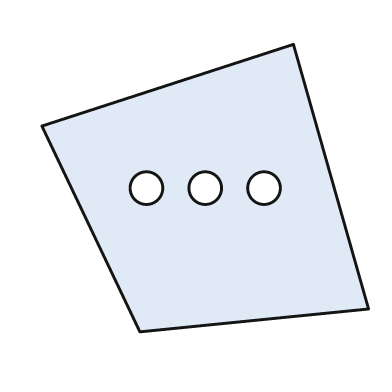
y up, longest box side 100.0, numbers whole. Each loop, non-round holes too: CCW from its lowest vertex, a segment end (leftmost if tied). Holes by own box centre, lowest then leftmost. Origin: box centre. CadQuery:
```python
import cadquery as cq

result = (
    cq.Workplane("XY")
    .moveTo(-20.0, -44.0)
    .lineTo(50.0, -37.0)
    .lineTo(27.0, 44.0)
    .lineTo(-50.0, 19.0)
    .close()
    .moveTo(-18.0, 0.0)
    .circle(5.0)
    .moveTo(0.0, 0.0)
    .circle(5.0)
    .moveTo(18.0, 0.0)
    .circle(5.0)
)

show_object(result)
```